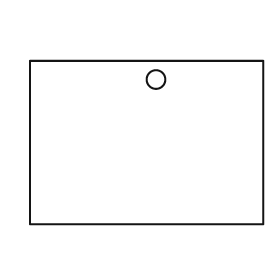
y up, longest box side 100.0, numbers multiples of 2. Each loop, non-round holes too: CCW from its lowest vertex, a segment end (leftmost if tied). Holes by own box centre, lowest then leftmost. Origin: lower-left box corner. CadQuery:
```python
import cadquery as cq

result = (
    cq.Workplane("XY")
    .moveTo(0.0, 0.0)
    .lineTo(100.0, 0.0)
    .lineTo(100.0, 70.0)
    .lineTo(0.0, 70.0)
    .close()
    .moveTo(54.0, 62.0)
    .circle(4.0)
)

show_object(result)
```